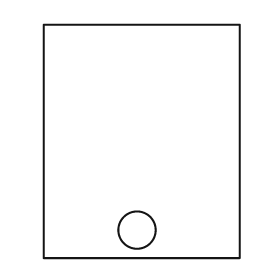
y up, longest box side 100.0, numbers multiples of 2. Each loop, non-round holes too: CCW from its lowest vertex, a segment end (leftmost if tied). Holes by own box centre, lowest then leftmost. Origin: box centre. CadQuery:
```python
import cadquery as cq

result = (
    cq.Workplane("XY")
    .moveTo(-42.0, -50.0)
    .lineTo(42.0, -50.0)
    .lineTo(42.0, 50.0)
    .lineTo(-42.0, 50.0)
    .close()
    .moveTo(-2.0, -38.0)
    .circle(8.0)
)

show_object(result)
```